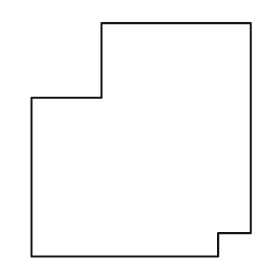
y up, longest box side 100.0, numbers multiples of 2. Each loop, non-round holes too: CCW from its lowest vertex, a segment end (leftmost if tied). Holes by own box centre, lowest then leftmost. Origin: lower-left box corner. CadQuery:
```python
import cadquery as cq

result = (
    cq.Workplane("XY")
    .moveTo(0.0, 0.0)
    .lineTo(80.0, 0.0)
    .lineTo(80.0, 10.0)
    .lineTo(94.0, 10.0)
    .lineTo(94.0, 100.0)
    .lineTo(30.0, 100.0)
    .lineTo(30.0, 68.0)
    .lineTo(0.0, 68.0)
    .close()
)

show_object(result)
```